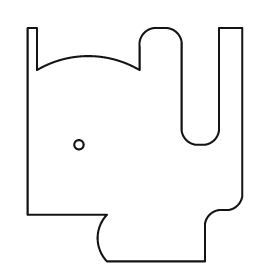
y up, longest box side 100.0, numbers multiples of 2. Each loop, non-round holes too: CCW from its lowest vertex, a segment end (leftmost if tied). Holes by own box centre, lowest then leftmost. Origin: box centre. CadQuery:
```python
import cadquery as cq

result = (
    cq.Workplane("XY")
    .moveTo(-12.0, -50.0)
    .lineTo(30.0, -50.0)
    .lineTo(30.0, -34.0)
    .threePointArc((32.0, -30.0), (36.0, -28.0))
    .lineTo(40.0, -28.0)
    .threePointArc((44.0, -26.0), (46.0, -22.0))
    .lineTo(46.0, 50.0)
    .lineTo(36.0, 50.0)
    .lineTo(36.0, 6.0)
    .threePointArc((34.0, 2.0), (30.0, 0.0))
    .lineTo(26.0, 0.0)
    .threePointArc((22.0, 2.0), (20.0, 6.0))
    .lineTo(20.0, 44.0)
    .threePointArc((18.0, 48.0), (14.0, 50.0))
    .lineTo(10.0, 50.0)
    .threePointArc((4.0, 48.0), (2.0, 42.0))
    .lineTo(2.0, 32.0)
    .threePointArc((-20.0, 38.0), (-42.0, 32.0))
    .lineTo(-42.0, 50.0)
    .lineTo(-46.0, 50.0)
    .lineTo(-46.0, -30.0)
    .lineTo(-12.0, -30.0)
    .threePointArc((-16.0, -40.0), (-12.0, -50.0))
    .close()
    .moveTo(-24.0, 0.0)
    .circle(2.0)
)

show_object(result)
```